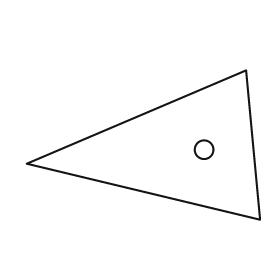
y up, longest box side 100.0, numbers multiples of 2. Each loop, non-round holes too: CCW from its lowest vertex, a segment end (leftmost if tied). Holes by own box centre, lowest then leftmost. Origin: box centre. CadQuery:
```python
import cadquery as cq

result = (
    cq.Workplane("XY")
    .moveTo(50.0, -32.0)
    .lineTo(44.0, 32.0)
    .lineTo(-50.0, -8.0)
    .close()
    .moveTo(26.0, -2.0)
    .circle(4.0)
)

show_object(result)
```